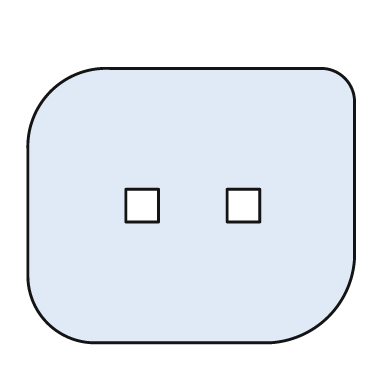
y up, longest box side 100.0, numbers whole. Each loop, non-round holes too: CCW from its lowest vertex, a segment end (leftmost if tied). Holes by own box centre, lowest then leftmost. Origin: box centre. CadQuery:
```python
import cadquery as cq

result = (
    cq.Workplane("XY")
    .moveTo(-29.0, -42.0)
    .lineTo(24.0, -42.0)
    .threePointArc((42.0, -34.0), (50.0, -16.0))
    .lineTo(50.0, 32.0)
    .threePointArc((47.0, 39.0), (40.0, 42.0))
    .lineTo(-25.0, 42.0)
    .threePointArc((-43.0, 35.0), (-50.0, 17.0))
    .lineTo(-50.0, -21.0)
    .threePointArc((-44.0, -36.0), (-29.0, -42.0))
    .close()
    .moveTo(-20.0, -5.0)
    .lineTo(-10.0, -5.0)
    .lineTo(-10.0, 5.0)
    .lineTo(-20.0, 5.0)
    .close()
    .moveTo(11.0, -5.0)
    .lineTo(21.0, -5.0)
    .lineTo(21.0, 5.0)
    .lineTo(11.0, 5.0)
    .close()
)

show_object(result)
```